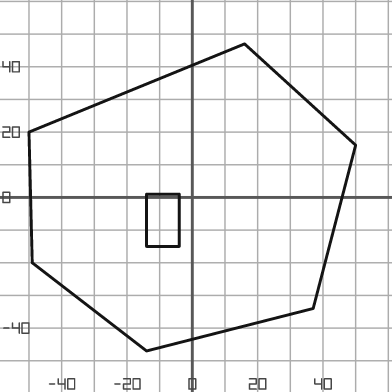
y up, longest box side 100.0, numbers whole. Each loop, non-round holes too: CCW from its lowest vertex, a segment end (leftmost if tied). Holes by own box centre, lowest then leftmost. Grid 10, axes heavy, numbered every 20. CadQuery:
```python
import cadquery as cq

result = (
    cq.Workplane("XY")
    .moveTo(-14.0, -47.0)
    .lineTo(37.0, -34.0)
    .lineTo(50.0, 16.0)
    .lineTo(16.0, 47.0)
    .lineTo(-50.0, 20.0)
    .lineTo(-49.0, -20.0)
    .close()
    .moveTo(-14.0, -15.0)
    .lineTo(-4.0, -15.0)
    .lineTo(-4.0, 1.0)
    .lineTo(-14.0, 1.0)
    .close()
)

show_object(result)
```